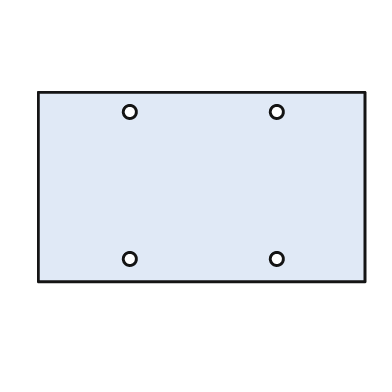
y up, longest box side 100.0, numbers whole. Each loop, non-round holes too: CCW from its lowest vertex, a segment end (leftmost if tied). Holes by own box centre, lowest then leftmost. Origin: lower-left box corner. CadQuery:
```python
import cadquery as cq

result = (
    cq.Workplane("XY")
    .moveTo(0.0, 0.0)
    .lineTo(100.0, 0.0)
    .lineTo(100.0, 58.0)
    .lineTo(0.0, 58.0)
    .close()
    .moveTo(28.0, 7.0)
    .circle(2.0)
    .moveTo(73.0, 7.0)
    .circle(2.0)
    .moveTo(28.0, 52.0)
    .circle(2.0)
    .moveTo(73.0, 52.0)
    .circle(2.0)
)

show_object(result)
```